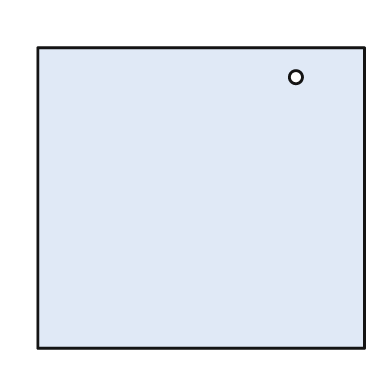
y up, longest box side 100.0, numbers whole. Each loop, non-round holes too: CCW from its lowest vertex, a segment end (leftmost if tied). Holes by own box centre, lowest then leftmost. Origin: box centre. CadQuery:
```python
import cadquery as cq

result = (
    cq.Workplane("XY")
    .moveTo(-50.0, -46.0)
    .lineTo(50.0, -46.0)
    .lineTo(50.0, 46.0)
    .lineTo(-50.0, 46.0)
    .close()
    .moveTo(29.0, 37.0)
    .circle(2.0)
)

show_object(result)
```